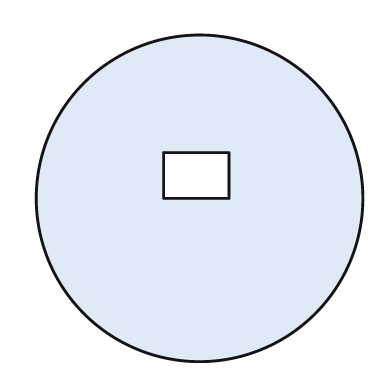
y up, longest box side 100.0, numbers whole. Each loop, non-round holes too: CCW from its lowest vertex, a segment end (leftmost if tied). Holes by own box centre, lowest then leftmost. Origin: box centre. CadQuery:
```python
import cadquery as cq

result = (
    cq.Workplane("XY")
    .moveTo(0.0, 0.0)
    .circle(50.0)
    .moveTo(-11.0, 0.0)
    .lineTo(9.0, 0.0)
    .lineTo(9.0, 14.0)
    .lineTo(-11.0, 14.0)
    .close()
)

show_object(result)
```